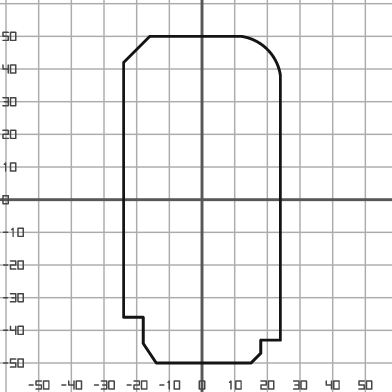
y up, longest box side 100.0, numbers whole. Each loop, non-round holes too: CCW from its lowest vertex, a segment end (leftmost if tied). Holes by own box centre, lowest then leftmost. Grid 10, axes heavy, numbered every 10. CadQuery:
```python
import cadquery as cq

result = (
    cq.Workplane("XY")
    .moveTo(-14.0, -50.0)
    .lineTo(15.0, -50.0)
    .lineTo(18.0, -47.0)
    .lineTo(18.0, -43.0)
    .lineTo(24.0, -43.0)
    .lineTo(24.0, 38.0)
    .threePointArc((20.0, 46.0), (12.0, 50.0))
    .lineTo(-16.0, 50.0)
    .lineTo(-24.0, 42.0)
    .lineTo(-24.0, -36.0)
    .lineTo(-18.0, -36.0)
    .lineTo(-18.0, -44.0)
    .close()
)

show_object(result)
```